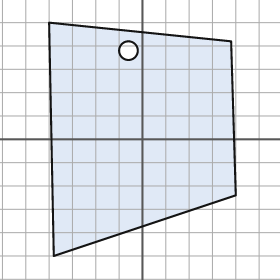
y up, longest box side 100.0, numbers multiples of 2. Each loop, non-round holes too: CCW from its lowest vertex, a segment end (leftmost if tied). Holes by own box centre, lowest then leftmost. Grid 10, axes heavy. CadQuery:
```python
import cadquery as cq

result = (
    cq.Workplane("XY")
    .moveTo(-38.0, -50.0)
    .lineTo(40.0, -24.0)
    .lineTo(38.0, 42.0)
    .lineTo(-40.0, 50.0)
    .close()
    .moveTo(-6.0, 38.0)
    .circle(4.0)
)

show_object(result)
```